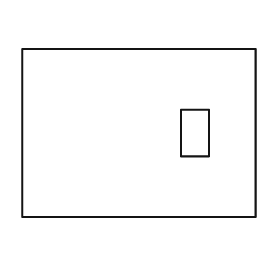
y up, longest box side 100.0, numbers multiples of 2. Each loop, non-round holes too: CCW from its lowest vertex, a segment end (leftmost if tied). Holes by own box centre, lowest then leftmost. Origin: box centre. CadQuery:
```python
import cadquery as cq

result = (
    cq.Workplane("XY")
    .moveTo(-50.0, -36.0)
    .lineTo(50.0, -36.0)
    .lineTo(50.0, 36.0)
    .lineTo(-50.0, 36.0)
    .close()
    .moveTo(18.0, -10.0)
    .lineTo(30.0, -10.0)
    .lineTo(30.0, 10.0)
    .lineTo(18.0, 10.0)
    .close()
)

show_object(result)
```